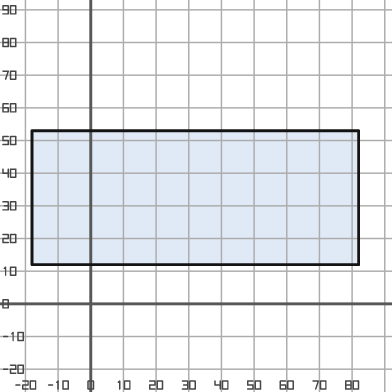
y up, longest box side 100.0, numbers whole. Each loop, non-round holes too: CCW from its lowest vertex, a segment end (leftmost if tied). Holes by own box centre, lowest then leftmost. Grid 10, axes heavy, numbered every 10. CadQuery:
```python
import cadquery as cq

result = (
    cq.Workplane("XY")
    .moveTo(-18.0, 12.0)
    .lineTo(82.0, 12.0)
    .lineTo(82.0, 53.0)
    .lineTo(-18.0, 53.0)
    .close()
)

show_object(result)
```